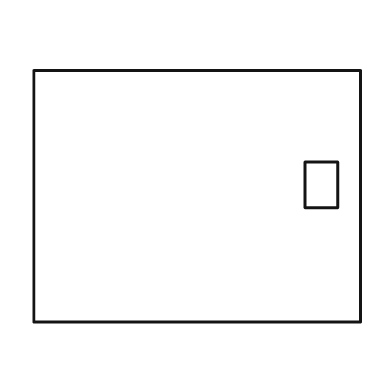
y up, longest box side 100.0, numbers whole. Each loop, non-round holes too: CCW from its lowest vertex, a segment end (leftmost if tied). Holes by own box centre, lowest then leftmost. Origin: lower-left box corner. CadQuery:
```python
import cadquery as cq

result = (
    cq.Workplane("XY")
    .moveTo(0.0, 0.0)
    .lineTo(100.0, 0.0)
    .lineTo(100.0, 77.0)
    .lineTo(0.0, 77.0)
    .close()
    .moveTo(83.0, 35.0)
    .lineTo(93.0, 35.0)
    .lineTo(93.0, 49.0)
    .lineTo(83.0, 49.0)
    .close()
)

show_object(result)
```